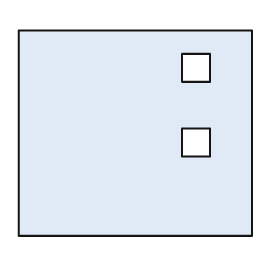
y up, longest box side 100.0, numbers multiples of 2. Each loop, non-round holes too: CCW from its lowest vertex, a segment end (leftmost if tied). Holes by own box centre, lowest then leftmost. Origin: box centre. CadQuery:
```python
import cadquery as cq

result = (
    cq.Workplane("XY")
    .moveTo(-50.0, -44.0)
    .lineTo(50.0, -44.0)
    .lineTo(50.0, 44.0)
    .lineTo(-50.0, 44.0)
    .close()
    .moveTo(20.0, -10.0)
    .lineTo(32.0, -10.0)
    .lineTo(32.0, 2.0)
    .lineTo(20.0, 2.0)
    .close()
    .moveTo(20.0, 22.0)
    .lineTo(32.0, 22.0)
    .lineTo(32.0, 34.0)
    .lineTo(20.0, 34.0)
    .close()
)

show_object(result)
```